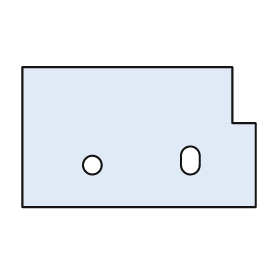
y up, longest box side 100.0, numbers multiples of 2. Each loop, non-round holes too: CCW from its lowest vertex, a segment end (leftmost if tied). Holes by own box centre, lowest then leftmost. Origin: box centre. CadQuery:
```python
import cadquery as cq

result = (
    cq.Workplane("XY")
    .moveTo(-50.0, -30.0)
    .lineTo(50.0, -30.0)
    .lineTo(50.0, 6.0)
    .lineTo(40.0, 6.0)
    .lineTo(40.0, 30.0)
    .lineTo(-50.0, 30.0)
    .close()
    .moveTo(-20.0, -12.0)
    .circle(4.0)
    .moveTo(18.0, -12.0)
    .threePointArc((22.0, -16.0), (26.0, -12.0))
    .lineTo(26.0, -8.0)
    .threePointArc((22.0, -4.0), (18.0, -8.0))
    .close()
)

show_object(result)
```